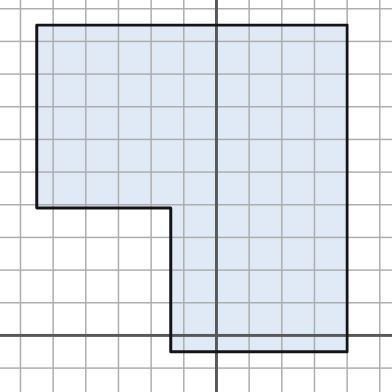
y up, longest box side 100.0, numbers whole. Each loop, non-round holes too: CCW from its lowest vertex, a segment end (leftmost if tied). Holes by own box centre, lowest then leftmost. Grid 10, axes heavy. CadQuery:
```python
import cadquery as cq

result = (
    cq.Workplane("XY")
    .moveTo(-14.0, -5.0)
    .lineTo(40.0, -5.0)
    .lineTo(40.0, 95.0)
    .lineTo(-55.0, 95.0)
    .lineTo(-55.0, 39.0)
    .lineTo(-14.0, 39.0)
    .close()
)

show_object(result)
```